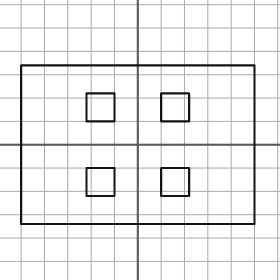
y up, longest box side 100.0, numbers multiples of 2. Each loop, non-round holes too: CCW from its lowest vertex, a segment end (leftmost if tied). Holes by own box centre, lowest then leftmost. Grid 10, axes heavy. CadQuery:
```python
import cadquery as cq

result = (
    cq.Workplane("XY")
    .moveTo(-50.0, -34.0)
    .lineTo(50.0, -34.0)
    .lineTo(50.0, 34.0)
    .lineTo(-50.0, 34.0)
    .close()
    .moveTo(-22.0, -22.0)
    .lineTo(-10.0, -22.0)
    .lineTo(-10.0, -10.0)
    .lineTo(-22.0, -10.0)
    .close()
    .moveTo(10.0, -22.0)
    .lineTo(22.0, -22.0)
    .lineTo(22.0, -10.0)
    .lineTo(10.0, -10.0)
    .close()
    .moveTo(-22.0, 10.0)
    .lineTo(-10.0, 10.0)
    .lineTo(-10.0, 22.0)
    .lineTo(-22.0, 22.0)
    .close()
    .moveTo(10.0, 10.0)
    .lineTo(22.0, 10.0)
    .lineTo(22.0, 22.0)
    .lineTo(10.0, 22.0)
    .close()
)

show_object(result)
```